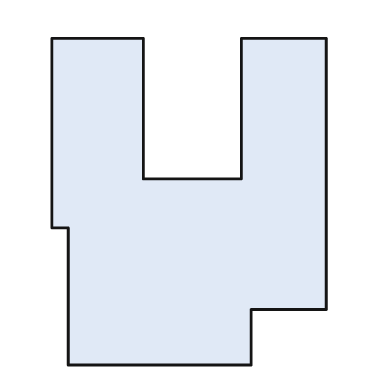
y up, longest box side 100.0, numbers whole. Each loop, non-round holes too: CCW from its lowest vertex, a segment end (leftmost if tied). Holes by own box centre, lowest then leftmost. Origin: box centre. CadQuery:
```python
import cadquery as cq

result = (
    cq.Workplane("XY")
    .moveTo(-37.0, -50.0)
    .lineTo(19.0, -50.0)
    .lineTo(19.0, -33.0)
    .lineTo(42.0, -33.0)
    .lineTo(42.0, 50.0)
    .lineTo(16.0, 50.0)
    .lineTo(16.0, 7.0)
    .lineTo(-14.0, 7.0)
    .lineTo(-14.0, 50.0)
    .lineTo(-42.0, 50.0)
    .lineTo(-42.0, -8.0)
    .lineTo(-37.0, -8.0)
    .close()
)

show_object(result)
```